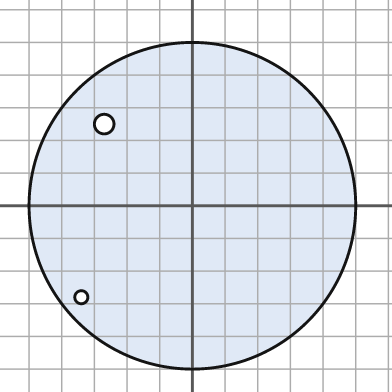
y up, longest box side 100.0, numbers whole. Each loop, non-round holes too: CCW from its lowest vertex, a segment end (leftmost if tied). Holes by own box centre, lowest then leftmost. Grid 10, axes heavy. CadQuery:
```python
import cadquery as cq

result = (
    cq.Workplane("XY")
    .moveTo(0.0, 0.0)
    .circle(50.0)
    .moveTo(-34.0, -28.0)
    .circle(2.0)
    .moveTo(-27.0, 25.0)
    .circle(3.0)
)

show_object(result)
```